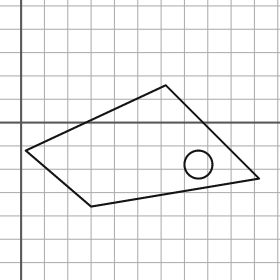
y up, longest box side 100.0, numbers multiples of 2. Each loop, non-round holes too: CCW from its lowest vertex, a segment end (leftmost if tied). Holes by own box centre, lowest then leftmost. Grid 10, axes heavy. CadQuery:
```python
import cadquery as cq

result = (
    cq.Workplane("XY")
    .moveTo(30.0, -36.0)
    .lineTo(102.0, -24.0)
    .lineTo(62.0, 16.0)
    .lineTo(2.0, -12.0)
    .close()
    .moveTo(76.0, -18.0)
    .circle(6.0)
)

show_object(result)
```